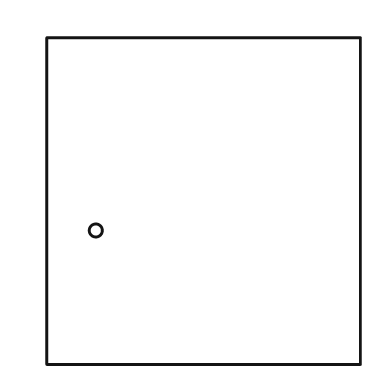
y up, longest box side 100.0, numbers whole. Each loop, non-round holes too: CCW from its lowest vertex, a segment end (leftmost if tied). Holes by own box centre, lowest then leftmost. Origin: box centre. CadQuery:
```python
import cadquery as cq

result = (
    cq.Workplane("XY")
    .moveTo(-48.0, -50.0)
    .lineTo(48.0, -50.0)
    .lineTo(48.0, 50.0)
    .lineTo(-48.0, 50.0)
    .close()
    .moveTo(-33.0, -9.0)
    .circle(2.0)
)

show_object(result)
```